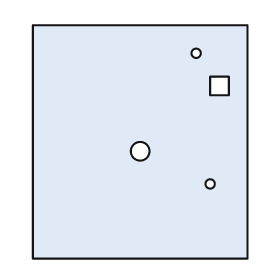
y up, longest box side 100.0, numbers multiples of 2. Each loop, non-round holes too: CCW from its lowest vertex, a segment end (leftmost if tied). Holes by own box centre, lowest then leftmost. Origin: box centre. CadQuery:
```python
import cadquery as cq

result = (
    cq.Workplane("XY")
    .moveTo(-46.0, -50.0)
    .lineTo(46.0, -50.0)
    .lineTo(46.0, 50.0)
    .lineTo(-46.0, 50.0)
    .close()
    .moveTo(30.0, -18.0)
    .circle(2.0)
    .moveTo(0.0, -4.0)
    .circle(4.0)
    .moveTo(30.0, 20.0)
    .lineTo(38.0, 20.0)
    .lineTo(38.0, 28.0)
    .lineTo(30.0, 28.0)
    .close()
    .moveTo(24.0, 38.0)
    .circle(2.0)
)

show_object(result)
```